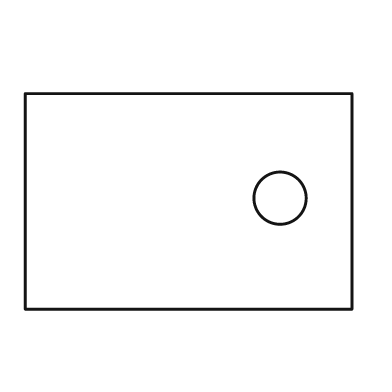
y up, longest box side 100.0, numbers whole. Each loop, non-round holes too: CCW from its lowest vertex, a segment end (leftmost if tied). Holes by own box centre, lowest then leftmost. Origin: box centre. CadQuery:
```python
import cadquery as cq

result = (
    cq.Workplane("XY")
    .moveTo(-50.0, -33.0)
    .lineTo(50.0, -33.0)
    .lineTo(50.0, 33.0)
    .lineTo(-50.0, 33.0)
    .close()
    .moveTo(28.0, 1.0)
    .circle(8.0)
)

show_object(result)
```